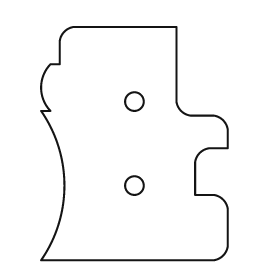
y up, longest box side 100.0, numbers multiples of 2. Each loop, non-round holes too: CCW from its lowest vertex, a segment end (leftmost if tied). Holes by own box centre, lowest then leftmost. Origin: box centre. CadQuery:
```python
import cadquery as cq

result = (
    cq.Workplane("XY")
    .moveTo(-40.0, -50.0)
    .lineTo(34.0, -50.0)
    .threePointArc((38.0, -48.0), (40.0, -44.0))
    .lineTo(40.0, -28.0)
    .threePointArc((38.0, -24.0), (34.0, -22.0))
    .lineTo(26.0, -22.0)
    .lineTo(26.0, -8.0)
    .threePointArc((28.0, -4.0), (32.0, -2.0))
    .lineTo(40.0, -2.0)
    .lineTo(40.0, 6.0)
    .threePointArc((38.0, 10.0), (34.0, 12.0))
    .lineTo(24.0, 12.0)
    .threePointArc((20.0, 14.0), (18.0, 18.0))
    .lineTo(18.0, 50.0)
    .lineTo(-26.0, 50.0)
    .threePointArc((-30.0, 48.0), (-32.0, 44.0))
    .lineTo(-32.0, 34.0)
    .lineTo(-36.0, 34.0)
    .threePointArc((-40.0, 24.0), (-36.0, 14.0))
    .lineTo(-40.0, 14.0)
    .threePointArc((-30.0, -18.0), (-40.0, -50.0))
    .close()
    .moveTo(0.0, -18.0)
    .circle(4.0)
    .moveTo(0.0, 18.0)
    .circle(4.0)
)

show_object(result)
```